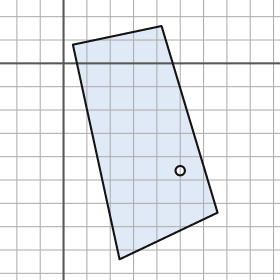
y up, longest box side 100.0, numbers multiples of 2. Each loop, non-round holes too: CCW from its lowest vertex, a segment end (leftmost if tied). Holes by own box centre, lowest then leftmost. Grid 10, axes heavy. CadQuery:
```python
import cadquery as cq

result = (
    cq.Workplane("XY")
    .moveTo(24.0, -84.0)
    .lineTo(66.0, -64.0)
    .lineTo(42.0, 16.0)
    .lineTo(4.0, 8.0)
    .close()
    .moveTo(50.0, -46.0)
    .circle(2.0)
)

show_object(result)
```